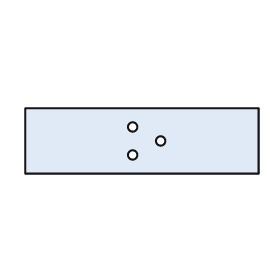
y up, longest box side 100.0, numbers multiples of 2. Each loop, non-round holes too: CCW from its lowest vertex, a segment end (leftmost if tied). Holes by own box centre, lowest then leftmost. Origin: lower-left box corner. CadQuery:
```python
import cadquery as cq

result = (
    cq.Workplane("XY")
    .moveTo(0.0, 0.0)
    .lineTo(100.0, 0.0)
    .lineTo(100.0, 28.0)
    .lineTo(0.0, 28.0)
    .close()
    .moveTo(46.0, 8.0)
    .circle(2.0)
    .moveTo(58.0, 14.0)
    .circle(2.0)
    .moveTo(46.0, 20.0)
    .circle(2.0)
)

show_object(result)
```